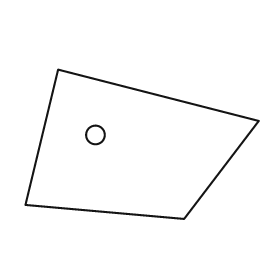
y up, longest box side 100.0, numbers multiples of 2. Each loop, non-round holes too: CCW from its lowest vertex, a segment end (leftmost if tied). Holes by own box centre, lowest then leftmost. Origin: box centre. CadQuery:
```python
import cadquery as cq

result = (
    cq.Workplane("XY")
    .moveTo(18.0, -32.0)
    .lineTo(50.0, 10.0)
    .lineTo(-36.0, 32.0)
    .lineTo(-50.0, -26.0)
    .close()
    .moveTo(-20.0, 4.0)
    .circle(4.0)
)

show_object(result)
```